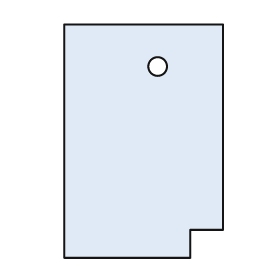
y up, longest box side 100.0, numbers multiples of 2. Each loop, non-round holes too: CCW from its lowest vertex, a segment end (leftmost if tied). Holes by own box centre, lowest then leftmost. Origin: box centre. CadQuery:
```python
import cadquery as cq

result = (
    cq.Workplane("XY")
    .moveTo(-34.0, -50.0)
    .lineTo(20.0, -50.0)
    .lineTo(20.0, -38.0)
    .lineTo(34.0, -38.0)
    .lineTo(34.0, 50.0)
    .lineTo(-34.0, 50.0)
    .close()
    .moveTo(6.0, 32.0)
    .circle(4.0)
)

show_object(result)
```